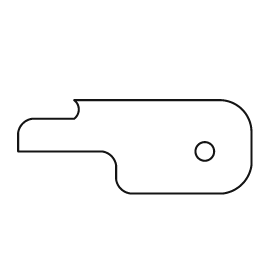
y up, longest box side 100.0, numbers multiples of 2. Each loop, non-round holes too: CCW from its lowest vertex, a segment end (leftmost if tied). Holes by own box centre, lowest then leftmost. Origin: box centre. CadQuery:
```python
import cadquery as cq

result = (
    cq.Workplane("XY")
    .moveTo(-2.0, -20.0)
    .lineTo(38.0, -20.0)
    .threePointArc((46.0, -16.0), (50.0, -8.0))
    .lineTo(50.0, 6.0)
    .threePointArc((46.0, 16.0), (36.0, 20.0))
    .lineTo(-26.0, 20.0)
    .threePointArc((-24.0, 16.0), (-26.0, 12.0))
    .lineTo(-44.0, 12.0)
    .threePointArc((-48.0, 10.0), (-50.0, 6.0))
    .lineTo(-50.0, -2.0)
    .lineTo(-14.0, -2.0)
    .threePointArc((-10.0, -4.0), (-8.0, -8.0))
    .lineTo(-8.0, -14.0)
    .threePointArc((-6.0, -18.0), (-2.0, -20.0))
    .close()
    .moveTo(30.0, -2.0)
    .circle(4.0)
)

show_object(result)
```